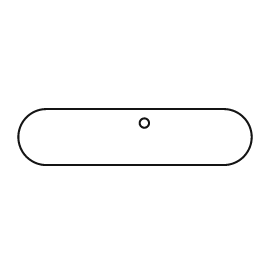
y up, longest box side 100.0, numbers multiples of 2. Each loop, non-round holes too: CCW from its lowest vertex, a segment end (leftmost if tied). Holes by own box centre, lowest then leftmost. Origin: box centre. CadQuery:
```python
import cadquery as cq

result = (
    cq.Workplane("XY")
    .moveTo(-38.0, -12.0)
    .lineTo(38.0, -12.0)
    .threePointArc((50.0, 0.0), (38.0, 12.0))
    .lineTo(-38.0, 12.0)
    .threePointArc((-50.0, 0.0), (-38.0, -12.0))
    .close()
    .moveTo(4.0, 6.0)
    .circle(2.0)
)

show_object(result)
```